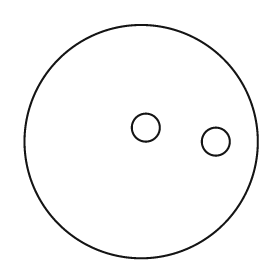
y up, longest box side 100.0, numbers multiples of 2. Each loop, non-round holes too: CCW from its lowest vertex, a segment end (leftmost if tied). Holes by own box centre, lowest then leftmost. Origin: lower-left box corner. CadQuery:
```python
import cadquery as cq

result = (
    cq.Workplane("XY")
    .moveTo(50.0, 50.0)
    .circle(50.0)
    .moveTo(82.0, 50.0)
    .circle(6.0)
    .moveTo(52.0, 56.0)
    .circle(6.0)
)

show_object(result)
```